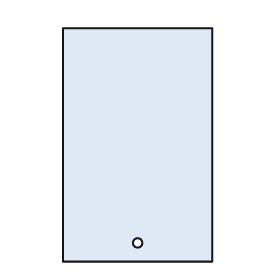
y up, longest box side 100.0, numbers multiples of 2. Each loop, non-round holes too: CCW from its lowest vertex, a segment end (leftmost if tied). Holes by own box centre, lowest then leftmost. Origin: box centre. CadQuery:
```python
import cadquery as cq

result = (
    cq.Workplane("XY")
    .moveTo(-32.0, -50.0)
    .lineTo(32.0, -50.0)
    .lineTo(32.0, 50.0)
    .lineTo(-32.0, 50.0)
    .close()
    .moveTo(0.0, -42.0)
    .circle(2.0)
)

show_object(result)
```